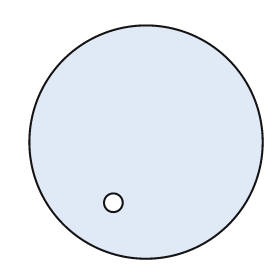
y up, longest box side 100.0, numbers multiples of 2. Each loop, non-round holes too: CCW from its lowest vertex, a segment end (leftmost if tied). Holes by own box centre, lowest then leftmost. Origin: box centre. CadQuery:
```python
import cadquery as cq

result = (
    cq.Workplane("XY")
    .moveTo(0.0, 0.0)
    .circle(50.0)
    .moveTo(-14.0, -26.0)
    .circle(4.0)
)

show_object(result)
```